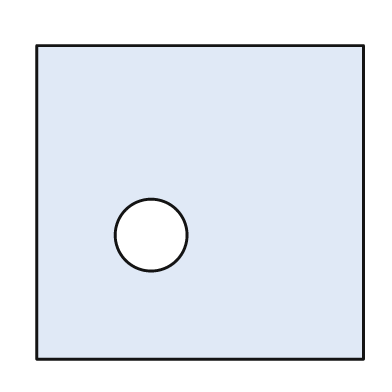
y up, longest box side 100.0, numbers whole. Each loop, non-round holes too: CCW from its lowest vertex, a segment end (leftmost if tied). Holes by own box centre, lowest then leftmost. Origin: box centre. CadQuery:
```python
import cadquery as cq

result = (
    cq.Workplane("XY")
    .moveTo(-50.0, -48.0)
    .lineTo(50.0, -48.0)
    .lineTo(50.0, 48.0)
    .lineTo(-50.0, 48.0)
    .close()
    .moveTo(-15.0, -10.0)
    .circle(11.0)
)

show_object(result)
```